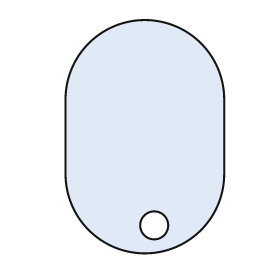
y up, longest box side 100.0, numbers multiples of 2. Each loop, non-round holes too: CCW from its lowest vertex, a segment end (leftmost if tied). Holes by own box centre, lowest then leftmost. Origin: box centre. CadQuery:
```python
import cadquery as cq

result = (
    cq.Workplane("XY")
    .moveTo(-34.0, -16.0)
    .threePointArc((0.0, -50.0), (34.0, -16.0))
    .lineTo(34.0, 16.0)
    .threePointArc((0.0, 50.0), (-34.0, 16.0))
    .close()
    .moveTo(4.0, -38.0)
    .circle(6.0)
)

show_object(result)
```